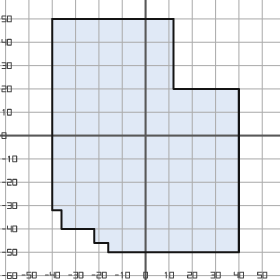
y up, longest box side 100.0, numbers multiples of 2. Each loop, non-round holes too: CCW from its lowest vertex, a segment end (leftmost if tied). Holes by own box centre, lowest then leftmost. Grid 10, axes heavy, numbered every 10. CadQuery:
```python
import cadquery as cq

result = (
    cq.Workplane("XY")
    .moveTo(-16.0, -50.0)
    .lineTo(40.0, -50.0)
    .lineTo(40.0, 20.0)
    .lineTo(12.0, 20.0)
    .lineTo(12.0, 50.0)
    .lineTo(-40.0, 50.0)
    .lineTo(-40.0, -32.0)
    .lineTo(-36.0, -32.0)
    .lineTo(-36.0, -40.0)
    .lineTo(-22.0, -40.0)
    .lineTo(-22.0, -46.0)
    .lineTo(-16.0, -46.0)
    .close()
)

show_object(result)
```